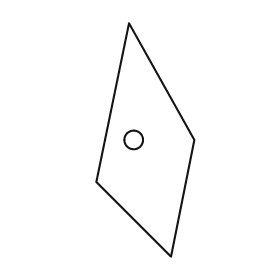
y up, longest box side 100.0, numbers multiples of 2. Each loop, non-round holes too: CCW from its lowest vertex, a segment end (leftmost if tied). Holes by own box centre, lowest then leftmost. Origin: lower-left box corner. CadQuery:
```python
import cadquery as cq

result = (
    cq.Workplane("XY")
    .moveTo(32.0, 0.0)
    .lineTo(42.0, 50.0)
    .lineTo(14.0, 100.0)
    .lineTo(0.0, 32.0)
    .close()
    .moveTo(16.0, 50.0)
    .circle(4.0)
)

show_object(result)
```